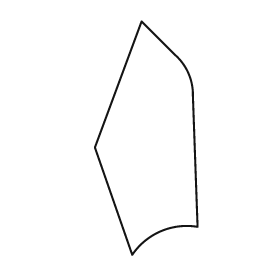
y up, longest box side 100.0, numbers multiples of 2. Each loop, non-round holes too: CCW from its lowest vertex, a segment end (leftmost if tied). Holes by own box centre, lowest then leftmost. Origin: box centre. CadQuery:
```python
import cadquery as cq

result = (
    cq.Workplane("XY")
    .moveTo(-6.0, -50.0)
    .threePointArc((6.0, -40.0), (22.0, -38.0))
    .lineTo(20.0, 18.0)
    .threePointArc((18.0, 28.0), (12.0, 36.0))
    .lineTo(-2.0, 50.0)
    .lineTo(-22.0, -4.0)
    .close()
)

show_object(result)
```